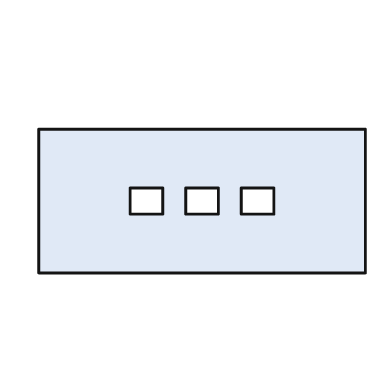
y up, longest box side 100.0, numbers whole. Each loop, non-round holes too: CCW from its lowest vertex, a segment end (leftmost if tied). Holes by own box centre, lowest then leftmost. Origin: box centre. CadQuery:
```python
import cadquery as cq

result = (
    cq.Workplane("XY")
    .moveTo(-50.0, -22.0)
    .lineTo(50.0, -22.0)
    .lineTo(50.0, 22.0)
    .lineTo(-50.0, 22.0)
    .close()
    .moveTo(-22.0, -4.0)
    .lineTo(-12.0, -4.0)
    .lineTo(-12.0, 4.0)
    .lineTo(-22.0, 4.0)
    .close()
    .moveTo(-5.0, -4.0)
    .lineTo(5.0, -4.0)
    .lineTo(5.0, 4.0)
    .lineTo(-5.0, 4.0)
    .close()
    .moveTo(12.0, -4.0)
    .lineTo(22.0, -4.0)
    .lineTo(22.0, 4.0)
    .lineTo(12.0, 4.0)
    .close()
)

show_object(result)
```